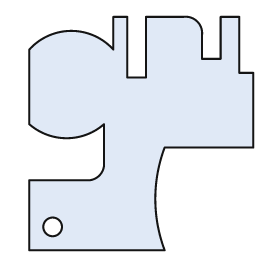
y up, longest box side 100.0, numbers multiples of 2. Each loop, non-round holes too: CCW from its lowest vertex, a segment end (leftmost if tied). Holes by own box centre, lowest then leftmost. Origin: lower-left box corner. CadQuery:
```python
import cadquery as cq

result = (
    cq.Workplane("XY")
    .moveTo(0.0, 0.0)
    .lineTo(58.0, 0.0)
    .threePointArc((54.0, 22.0), (58.0, 44.0))
    .lineTo(96.0, 44.0)
    .lineTo(96.0, 76.0)
    .lineTo(90.0, 76.0)
    .lineTo(90.0, 100.0)
    .lineTo(82.0, 100.0)
    .lineTo(82.0, 82.0)
    .lineTo(74.0, 82.0)
    .lineTo(74.0, 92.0)
    .threePointArc((72.0, 98.0), (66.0, 100.0))
    .lineTo(50.0, 100.0)
    .lineTo(50.0, 74.0)
    .lineTo(42.0, 74.0)
    .lineTo(42.0, 100.0)
    .lineTo(36.0, 100.0)
    .lineTo(36.0, 86.0)
    .threePointArc((18.0, 94.0), (0.0, 86.0))
    .lineTo(0.0, 54.0)
    .threePointArc((16.0, 48.0), (32.0, 54.0))
    .lineTo(32.0, 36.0)
    .threePointArc((30.0, 32.0), (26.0, 30.0))
    .lineTo(0.0, 30.0)
    .close()
    .moveTo(10.0, 10.0)
    .circle(4.0)
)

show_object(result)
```